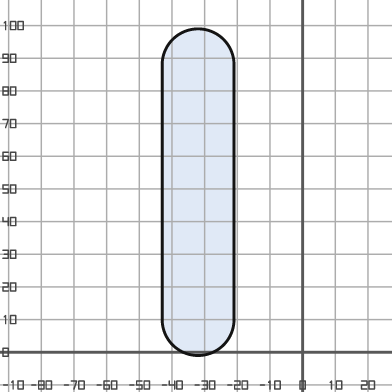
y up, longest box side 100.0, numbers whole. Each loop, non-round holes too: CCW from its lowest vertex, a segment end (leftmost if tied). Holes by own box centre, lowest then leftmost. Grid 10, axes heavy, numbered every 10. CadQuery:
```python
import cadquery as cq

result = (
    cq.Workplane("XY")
    .moveTo(-43.0, 10.0)
    .threePointArc((-32.0, -1.0), (-21.0, 10.0))
    .lineTo(-21.0, 88.0)
    .threePointArc((-32.0, 99.0), (-43.0, 88.0))
    .close()
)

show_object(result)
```